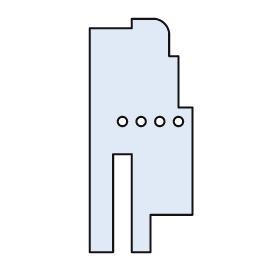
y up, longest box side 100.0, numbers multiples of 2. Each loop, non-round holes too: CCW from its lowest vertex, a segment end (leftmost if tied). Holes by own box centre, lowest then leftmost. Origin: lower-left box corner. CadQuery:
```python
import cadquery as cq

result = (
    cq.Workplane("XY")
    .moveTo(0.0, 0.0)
    .lineTo(10.0, 0.0)
    .lineTo(10.0, 42.0)
    .lineTo(18.0, 42.0)
    .lineTo(18.0, 0.0)
    .lineTo(26.0, 0.0)
    .lineTo(26.0, 16.0)
    .lineTo(44.0, 16.0)
    .lineTo(44.0, 62.0)
    .lineTo(38.0, 62.0)
    .lineTo(38.0, 84.0)
    .lineTo(34.0, 84.0)
    .lineTo(34.0, 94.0)
    .threePointArc((32.0, 98.0), (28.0, 100.0))
    .lineTo(18.0, 100.0)
    .lineTo(18.0, 96.0)
    .lineTo(0.0, 96.0)
    .close()
    .moveTo(14.0, 56.0)
    .circle(2.0)
    .moveTo(22.0, 56.0)
    .circle(2.0)
    .moveTo(30.0, 56.0)
    .circle(2.0)
    .moveTo(38.0, 56.0)
    .circle(2.0)
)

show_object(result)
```